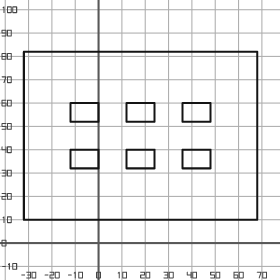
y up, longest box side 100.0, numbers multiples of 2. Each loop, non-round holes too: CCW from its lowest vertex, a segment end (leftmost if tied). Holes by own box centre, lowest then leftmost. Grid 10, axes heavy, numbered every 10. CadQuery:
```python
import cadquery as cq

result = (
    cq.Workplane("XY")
    .moveTo(-32.0, 10.0)
    .lineTo(68.0, 10.0)
    .lineTo(68.0, 82.0)
    .lineTo(-32.0, 82.0)
    .close()
    .moveTo(-12.0, 32.0)
    .lineTo(0.0, 32.0)
    .lineTo(0.0, 40.0)
    .lineTo(-12.0, 40.0)
    .close()
    .moveTo(12.0, 32.0)
    .lineTo(24.0, 32.0)
    .lineTo(24.0, 40.0)
    .lineTo(12.0, 40.0)
    .close()
    .moveTo(36.0, 32.0)
    .lineTo(48.0, 32.0)
    .lineTo(48.0, 40.0)
    .lineTo(36.0, 40.0)
    .close()
    .moveTo(-12.0, 52.0)
    .lineTo(0.0, 52.0)
    .lineTo(0.0, 60.0)
    .lineTo(-12.0, 60.0)
    .close()
    .moveTo(12.0, 52.0)
    .lineTo(24.0, 52.0)
    .lineTo(24.0, 60.0)
    .lineTo(12.0, 60.0)
    .close()
    .moveTo(36.0, 52.0)
    .lineTo(48.0, 52.0)
    .lineTo(48.0, 60.0)
    .lineTo(36.0, 60.0)
    .close()
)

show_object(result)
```